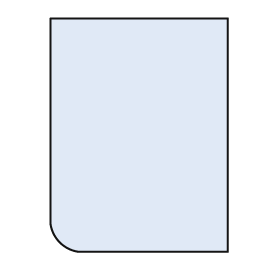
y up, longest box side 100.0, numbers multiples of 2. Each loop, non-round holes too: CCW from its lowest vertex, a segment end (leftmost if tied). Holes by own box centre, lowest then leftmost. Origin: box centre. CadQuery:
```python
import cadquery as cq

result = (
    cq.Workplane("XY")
    .moveTo(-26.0, -50.0)
    .lineTo(38.0, -50.0)
    .lineTo(38.0, 50.0)
    .lineTo(-38.0, 50.0)
    .lineTo(-38.0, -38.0)
    .threePointArc((-34.0, -46.0), (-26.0, -50.0))
    .close()
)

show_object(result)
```